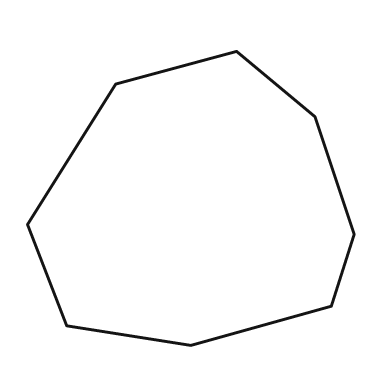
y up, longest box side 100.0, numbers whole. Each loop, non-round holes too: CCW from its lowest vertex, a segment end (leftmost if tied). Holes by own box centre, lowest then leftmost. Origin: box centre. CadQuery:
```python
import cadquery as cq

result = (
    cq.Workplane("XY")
    .moveTo(0.0, -45.0)
    .lineTo(43.0, -33.0)
    .lineTo(50.0, -11.0)
    .lineTo(38.0, 25.0)
    .lineTo(14.0, 45.0)
    .lineTo(-23.0, 35.0)
    .lineTo(-50.0, -8.0)
    .lineTo(-38.0, -39.0)
    .close()
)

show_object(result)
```